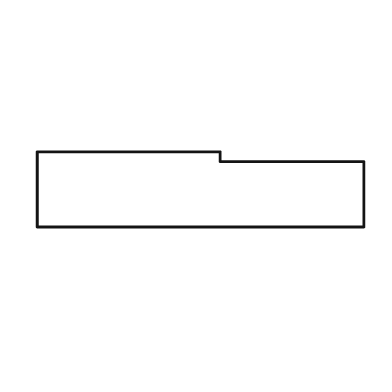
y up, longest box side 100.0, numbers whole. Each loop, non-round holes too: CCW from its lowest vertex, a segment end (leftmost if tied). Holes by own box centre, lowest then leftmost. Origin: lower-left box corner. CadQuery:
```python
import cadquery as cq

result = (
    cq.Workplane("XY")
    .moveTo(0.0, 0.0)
    .lineTo(100.0, 0.0)
    .lineTo(100.0, 20.0)
    .lineTo(56.0, 20.0)
    .lineTo(56.0, 23.0)
    .lineTo(0.0, 23.0)
    .close()
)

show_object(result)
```